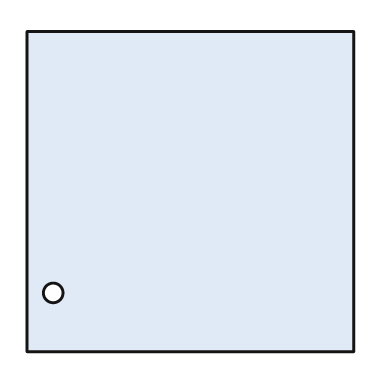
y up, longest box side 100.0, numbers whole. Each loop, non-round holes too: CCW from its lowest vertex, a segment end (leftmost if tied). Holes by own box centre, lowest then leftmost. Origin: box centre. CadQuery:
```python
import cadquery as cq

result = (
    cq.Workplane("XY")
    .moveTo(-50.0, -49.0)
    .lineTo(50.0, -49.0)
    .lineTo(50.0, 49.0)
    .lineTo(-50.0, 49.0)
    .close()
    .moveTo(-42.0, -31.0)
    .circle(3.0)
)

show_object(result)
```